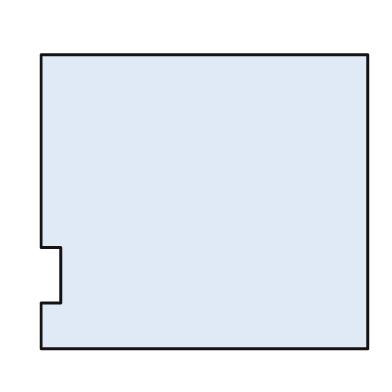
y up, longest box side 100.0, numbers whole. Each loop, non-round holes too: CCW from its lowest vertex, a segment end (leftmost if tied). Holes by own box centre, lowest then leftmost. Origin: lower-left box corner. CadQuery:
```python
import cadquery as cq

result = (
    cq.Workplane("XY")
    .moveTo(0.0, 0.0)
    .lineTo(100.0, 0.0)
    .lineTo(100.0, 90.0)
    .lineTo(0.0, 90.0)
    .lineTo(0.0, 31.0)
    .lineTo(6.0, 31.0)
    .lineTo(6.0, 14.0)
    .lineTo(0.0, 14.0)
    .close()
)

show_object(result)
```